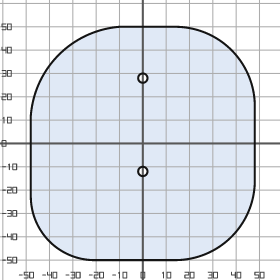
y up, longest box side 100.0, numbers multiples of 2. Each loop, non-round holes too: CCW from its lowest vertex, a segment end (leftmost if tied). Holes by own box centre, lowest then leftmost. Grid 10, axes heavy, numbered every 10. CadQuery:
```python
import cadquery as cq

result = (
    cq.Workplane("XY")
    .moveTo(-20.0, -50.0)
    .lineTo(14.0, -50.0)
    .threePointArc((38.0, -40.0), (48.0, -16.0))
    .lineTo(48.0, 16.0)
    .threePointArc((38.0, 40.0), (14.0, 50.0))
    .lineTo(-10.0, 50.0)
    .threePointArc((-36.0, 38.0), (-48.0, 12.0))
    .lineTo(-48.0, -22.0)
    .threePointArc((-40.0, -42.0), (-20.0, -50.0))
    .close()
    .moveTo(0.0, -12.0)
    .circle(2.0)
    .moveTo(0.0, 28.0)
    .circle(2.0)
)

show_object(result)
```